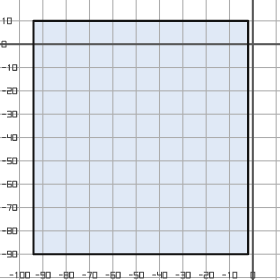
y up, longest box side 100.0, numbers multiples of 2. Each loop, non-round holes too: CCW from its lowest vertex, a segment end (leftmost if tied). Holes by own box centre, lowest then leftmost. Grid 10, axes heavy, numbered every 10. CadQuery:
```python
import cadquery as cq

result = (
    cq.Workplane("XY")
    .moveTo(-94.0, -90.0)
    .lineTo(-2.0, -90.0)
    .lineTo(-2.0, 10.0)
    .lineTo(-94.0, 10.0)
    .close()
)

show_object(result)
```